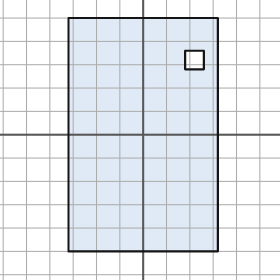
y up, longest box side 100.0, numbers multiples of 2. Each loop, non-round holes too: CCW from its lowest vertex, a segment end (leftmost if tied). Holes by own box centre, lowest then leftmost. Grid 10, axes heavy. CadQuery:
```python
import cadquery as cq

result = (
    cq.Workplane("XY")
    .moveTo(-32.0, -50.0)
    .lineTo(32.0, -50.0)
    .lineTo(32.0, 50.0)
    .lineTo(-32.0, 50.0)
    .close()
    .moveTo(18.0, 28.0)
    .lineTo(26.0, 28.0)
    .lineTo(26.0, 36.0)
    .lineTo(18.0, 36.0)
    .close()
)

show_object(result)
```